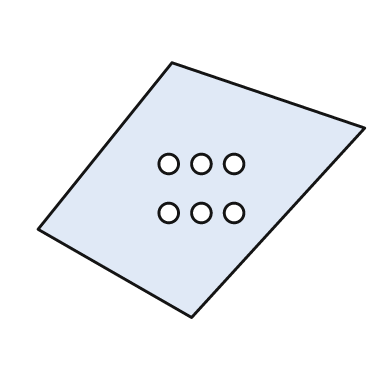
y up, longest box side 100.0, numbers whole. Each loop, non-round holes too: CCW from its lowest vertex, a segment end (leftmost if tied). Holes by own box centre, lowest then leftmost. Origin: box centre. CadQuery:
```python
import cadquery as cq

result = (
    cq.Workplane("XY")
    .moveTo(-3.0, -39.0)
    .lineTo(50.0, 19.0)
    .lineTo(-9.0, 39.0)
    .lineTo(-50.0, -12.0)
    .close()
    .moveTo(-10.0, -7.0)
    .circle(3.0)
    .moveTo(0.0, -7.0)
    .circle(3.0)
    .moveTo(10.0, -7.0)
    .circle(3.0)
    .moveTo(-10.0, 8.0)
    .circle(3.0)
    .moveTo(0.0, 8.0)
    .circle(3.0)
    .moveTo(10.0, 8.0)
    .circle(3.0)
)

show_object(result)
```